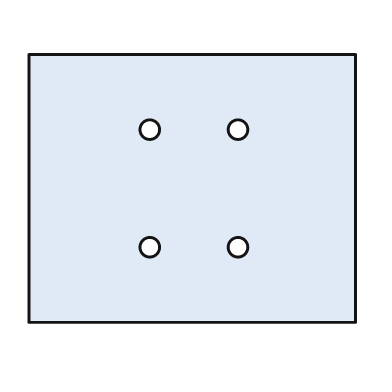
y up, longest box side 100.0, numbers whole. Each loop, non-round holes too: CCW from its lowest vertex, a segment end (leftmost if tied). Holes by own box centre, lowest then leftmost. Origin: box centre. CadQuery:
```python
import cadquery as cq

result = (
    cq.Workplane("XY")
    .moveTo(-50.0, -41.0)
    .lineTo(50.0, -41.0)
    .lineTo(50.0, 41.0)
    .lineTo(-50.0, 41.0)
    .close()
    .moveTo(-13.0, -18.0)
    .circle(3.0)
    .moveTo(14.0, -18.0)
    .circle(3.0)
    .moveTo(-13.0, 18.0)
    .circle(3.0)
    .moveTo(14.0, 18.0)
    .circle(3.0)
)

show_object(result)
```